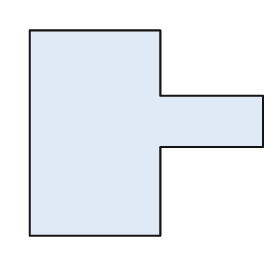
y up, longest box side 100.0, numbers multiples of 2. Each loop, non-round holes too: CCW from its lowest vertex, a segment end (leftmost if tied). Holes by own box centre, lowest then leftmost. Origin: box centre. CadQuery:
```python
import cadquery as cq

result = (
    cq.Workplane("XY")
    .moveTo(-50.0, -44.0)
    .lineTo(6.0, -44.0)
    .lineTo(6.0, -6.0)
    .lineTo(50.0, -6.0)
    .lineTo(50.0, 16.0)
    .lineTo(6.0, 16.0)
    .lineTo(6.0, 44.0)
    .lineTo(-50.0, 44.0)
    .close()
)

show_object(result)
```